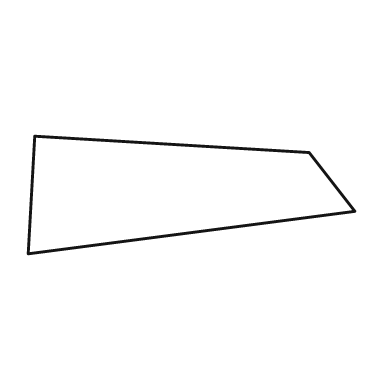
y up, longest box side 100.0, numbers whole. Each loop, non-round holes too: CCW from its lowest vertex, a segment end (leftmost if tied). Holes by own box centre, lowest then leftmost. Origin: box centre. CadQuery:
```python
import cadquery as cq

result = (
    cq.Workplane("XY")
    .moveTo(-50.0, -18.0)
    .lineTo(50.0, -5.0)
    .lineTo(36.0, 13.0)
    .lineTo(-48.0, 18.0)
    .close()
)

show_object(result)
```